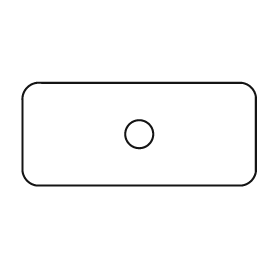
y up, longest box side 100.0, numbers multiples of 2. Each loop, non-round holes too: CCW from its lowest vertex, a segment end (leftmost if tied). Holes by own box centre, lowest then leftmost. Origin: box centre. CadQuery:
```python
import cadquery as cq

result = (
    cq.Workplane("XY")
    .moveTo(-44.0, -22.0)
    .lineTo(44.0, -22.0)
    .threePointArc((48.0, -20.0), (50.0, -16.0))
    .lineTo(50.0, 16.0)
    .threePointArc((48.0, 20.0), (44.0, 22.0))
    .lineTo(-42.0, 22.0)
    .threePointArc((-48.0, 20.0), (-50.0, 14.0))
    .lineTo(-50.0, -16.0)
    .threePointArc((-48.0, -20.0), (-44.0, -22.0))
    .close()
    .moveTo(0.0, 0.0)
    .circle(6.0)
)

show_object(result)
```